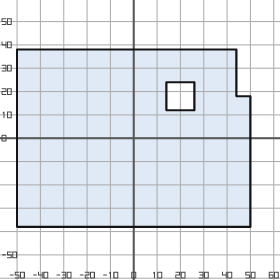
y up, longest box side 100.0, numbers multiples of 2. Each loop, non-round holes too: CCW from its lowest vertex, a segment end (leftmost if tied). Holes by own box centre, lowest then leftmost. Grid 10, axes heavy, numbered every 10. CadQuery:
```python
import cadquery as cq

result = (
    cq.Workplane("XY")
    .moveTo(-50.0, -38.0)
    .lineTo(50.0, -38.0)
    .lineTo(50.0, 18.0)
    .lineTo(44.0, 18.0)
    .lineTo(44.0, 38.0)
    .lineTo(-50.0, 38.0)
    .close()
    .moveTo(14.0, 12.0)
    .lineTo(26.0, 12.0)
    .lineTo(26.0, 24.0)
    .lineTo(14.0, 24.0)
    .close()
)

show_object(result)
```